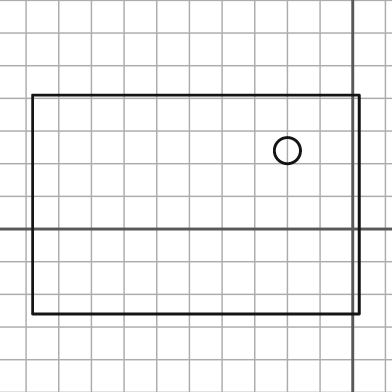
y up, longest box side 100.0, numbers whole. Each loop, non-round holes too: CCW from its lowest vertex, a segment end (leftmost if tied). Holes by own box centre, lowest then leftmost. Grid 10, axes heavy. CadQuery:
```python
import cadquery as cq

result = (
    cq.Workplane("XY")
    .moveTo(-98.0, -26.0)
    .lineTo(2.0, -26.0)
    .lineTo(2.0, 41.0)
    .lineTo(-98.0, 41.0)
    .close()
    .moveTo(-20.0, 24.0)
    .circle(4.0)
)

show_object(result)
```